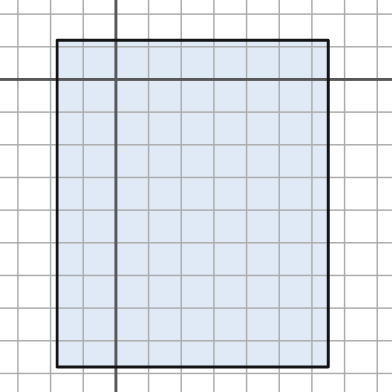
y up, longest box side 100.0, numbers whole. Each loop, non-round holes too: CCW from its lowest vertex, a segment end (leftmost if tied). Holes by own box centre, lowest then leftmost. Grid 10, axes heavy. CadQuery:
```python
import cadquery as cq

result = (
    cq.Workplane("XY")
    .moveTo(-18.0, -88.0)
    .lineTo(65.0, -88.0)
    .lineTo(65.0, 12.0)
    .lineTo(-18.0, 12.0)
    .close()
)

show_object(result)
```